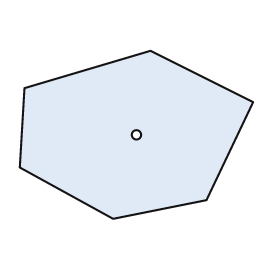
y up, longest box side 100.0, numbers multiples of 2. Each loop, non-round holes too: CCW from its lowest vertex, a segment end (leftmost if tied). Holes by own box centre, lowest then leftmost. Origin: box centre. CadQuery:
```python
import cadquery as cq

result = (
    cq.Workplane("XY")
    .moveTo(-10.0, -36.0)
    .lineTo(30.0, -28.0)
    .lineTo(50.0, 14.0)
    .lineTo(6.0, 36.0)
    .lineTo(-48.0, 20.0)
    .lineTo(-50.0, -14.0)
    .close()
    .moveTo(0.0, 0.0)
    .circle(2.0)
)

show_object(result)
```